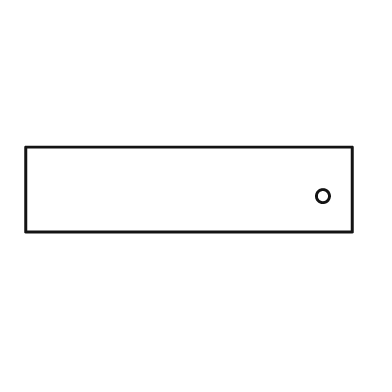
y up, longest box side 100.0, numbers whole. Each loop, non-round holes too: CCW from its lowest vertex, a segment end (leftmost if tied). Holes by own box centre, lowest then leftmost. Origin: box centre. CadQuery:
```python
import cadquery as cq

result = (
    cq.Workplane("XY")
    .moveTo(-50.0, -13.0)
    .lineTo(50.0, -13.0)
    .lineTo(50.0, 13.0)
    .lineTo(-50.0, 13.0)
    .close()
    .moveTo(41.0, -2.0)
    .circle(2.0)
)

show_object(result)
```